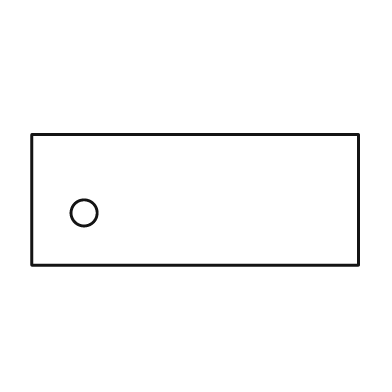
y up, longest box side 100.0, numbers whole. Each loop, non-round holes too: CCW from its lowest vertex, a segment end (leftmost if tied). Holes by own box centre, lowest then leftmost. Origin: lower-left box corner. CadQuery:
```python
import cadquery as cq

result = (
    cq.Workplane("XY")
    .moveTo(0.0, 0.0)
    .lineTo(100.0, 0.0)
    .lineTo(100.0, 40.0)
    .lineTo(0.0, 40.0)
    .close()
    .moveTo(16.0, 16.0)
    .circle(4.0)
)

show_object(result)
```